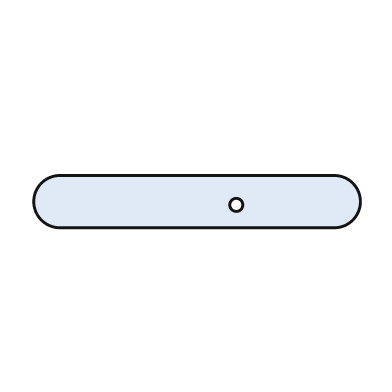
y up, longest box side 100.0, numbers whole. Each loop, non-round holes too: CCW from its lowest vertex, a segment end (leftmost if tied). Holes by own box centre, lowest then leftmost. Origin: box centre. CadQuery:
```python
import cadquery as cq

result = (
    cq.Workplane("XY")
    .moveTo(-42.0, -8.0)
    .lineTo(42.0, -8.0)
    .threePointArc((50.0, 0.0), (42.0, 8.0))
    .lineTo(-42.0, 8.0)
    .threePointArc((-50.0, 0.0), (-42.0, -8.0))
    .close()
    .moveTo(12.0, -1.0)
    .circle(2.0)
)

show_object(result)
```